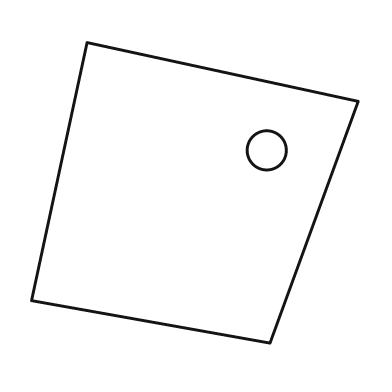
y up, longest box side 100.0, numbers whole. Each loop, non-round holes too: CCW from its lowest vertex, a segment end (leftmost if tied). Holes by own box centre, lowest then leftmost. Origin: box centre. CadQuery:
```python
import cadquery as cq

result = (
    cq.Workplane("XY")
    .moveTo(23.0, -46.0)
    .lineTo(50.0, 28.0)
    .lineTo(-33.0, 46.0)
    .lineTo(-50.0, -33.0)
    .close()
    .moveTo(22.0, 13.0)
    .circle(6.0)
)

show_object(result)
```